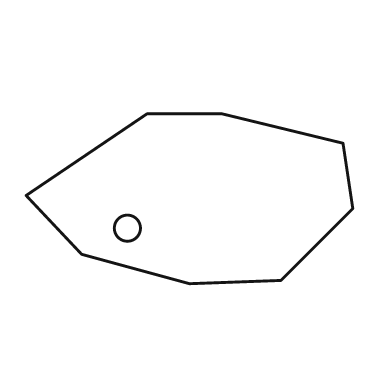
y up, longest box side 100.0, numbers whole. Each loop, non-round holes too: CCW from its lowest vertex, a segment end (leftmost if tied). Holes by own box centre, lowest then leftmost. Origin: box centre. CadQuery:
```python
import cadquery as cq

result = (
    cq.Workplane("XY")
    .moveTo(0.0, -26.0)
    .lineTo(28.0, -25.0)
    .lineTo(50.0, -3.0)
    .lineTo(47.0, 17.0)
    .lineTo(10.0, 26.0)
    .lineTo(-13.0, 26.0)
    .lineTo(-50.0, 1.0)
    .lineTo(-33.0, -17.0)
    .close()
    .moveTo(-19.0, -9.0)
    .circle(4.0)
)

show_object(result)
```